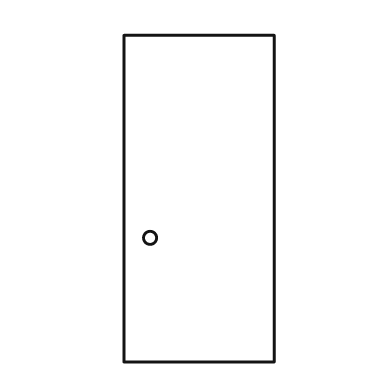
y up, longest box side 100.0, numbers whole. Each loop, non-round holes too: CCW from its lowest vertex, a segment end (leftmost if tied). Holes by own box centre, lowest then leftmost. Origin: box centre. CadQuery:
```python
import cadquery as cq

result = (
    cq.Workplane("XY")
    .moveTo(-23.0, -50.0)
    .lineTo(23.0, -50.0)
    .lineTo(23.0, 50.0)
    .lineTo(-23.0, 50.0)
    .close()
    .moveTo(-15.0, -12.0)
    .circle(2.0)
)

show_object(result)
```